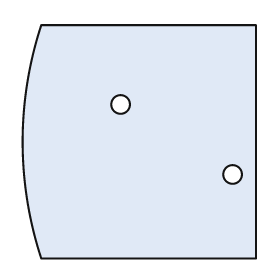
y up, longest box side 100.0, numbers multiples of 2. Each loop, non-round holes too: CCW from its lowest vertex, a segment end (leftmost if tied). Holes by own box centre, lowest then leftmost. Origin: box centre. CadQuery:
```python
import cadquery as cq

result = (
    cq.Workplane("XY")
    .moveTo(-42.0, -50.0)
    .lineTo(50.0, -50.0)
    .lineTo(50.0, 50.0)
    .lineTo(-42.0, 50.0)
    .threePointArc((-50.0, 0.0), (-42.0, -50.0))
    .close()
    .moveTo(40.0, -14.0)
    .circle(4.0)
    .moveTo(-8.0, 16.0)
    .circle(4.0)
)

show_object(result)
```